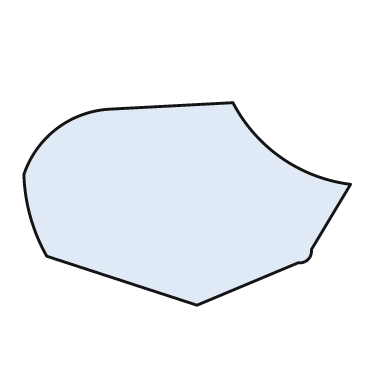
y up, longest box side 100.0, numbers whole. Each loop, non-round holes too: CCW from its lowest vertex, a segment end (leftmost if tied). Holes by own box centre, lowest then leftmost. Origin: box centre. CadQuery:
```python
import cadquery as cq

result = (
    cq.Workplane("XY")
    .moveTo(3.0, -31.0)
    .lineTo(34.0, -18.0)
    .threePointArc((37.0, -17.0), (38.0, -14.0))
    .lineTo(50.0, 6.0)
    .threePointArc((29.0, 14.0), (14.0, 31.0))
    .lineTo(-24.0, 29.0)
    .threePointArc((-40.0, 23.0), (-50.0, 9.0))
    .threePointArc((-48.0, -4.0), (-43.0, -16.0))
    .close()
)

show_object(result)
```